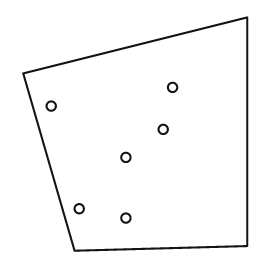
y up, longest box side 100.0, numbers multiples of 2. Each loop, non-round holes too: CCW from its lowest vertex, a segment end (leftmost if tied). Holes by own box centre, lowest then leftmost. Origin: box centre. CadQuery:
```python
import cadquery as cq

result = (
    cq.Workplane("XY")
    .moveTo(-26.0, -50.0)
    .lineTo(48.0, -48.0)
    .lineTo(48.0, 50.0)
    .lineTo(-48.0, 26.0)
    .close()
    .moveTo(-4.0, -36.0)
    .circle(2.0)
    .moveTo(-24.0, -32.0)
    .circle(2.0)
    .moveTo(-4.0, -10.0)
    .circle(2.0)
    .moveTo(12.0, 2.0)
    .circle(2.0)
    .moveTo(-36.0, 12.0)
    .circle(2.0)
    .moveTo(16.0, 20.0)
    .circle(2.0)
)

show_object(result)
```